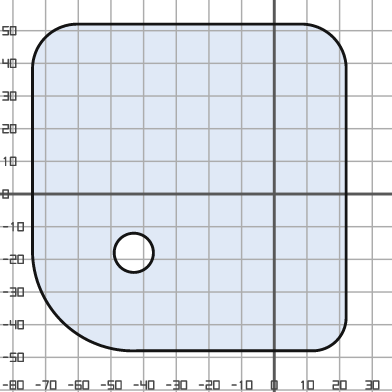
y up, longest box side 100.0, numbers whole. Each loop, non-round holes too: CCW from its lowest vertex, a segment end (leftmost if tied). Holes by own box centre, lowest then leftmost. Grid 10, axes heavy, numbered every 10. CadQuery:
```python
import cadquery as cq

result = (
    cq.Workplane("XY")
    .moveTo(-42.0, -48.0)
    .lineTo(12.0, -48.0)
    .threePointArc((19.0, -45.0), (22.0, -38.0))
    .lineTo(22.0, 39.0)
    .threePointArc((18.0, 48.0), (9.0, 52.0))
    .lineTo(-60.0, 52.0)
    .threePointArc((-70.0, 48.0), (-74.0, 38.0))
    .lineTo(-74.0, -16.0)
    .threePointArc((-65.0, -39.0), (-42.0, -48.0))
    .close()
    .moveTo(-43.0, -18.0)
    .circle(6.0)
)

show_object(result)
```